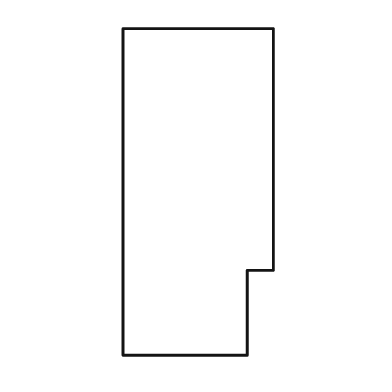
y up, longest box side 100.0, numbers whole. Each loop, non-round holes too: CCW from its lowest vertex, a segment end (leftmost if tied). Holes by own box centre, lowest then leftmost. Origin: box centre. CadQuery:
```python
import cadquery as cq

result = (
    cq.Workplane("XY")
    .moveTo(-23.0, -50.0)
    .lineTo(15.0, -50.0)
    .lineTo(15.0, -24.0)
    .lineTo(23.0, -24.0)
    .lineTo(23.0, 50.0)
    .lineTo(-23.0, 50.0)
    .close()
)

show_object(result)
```